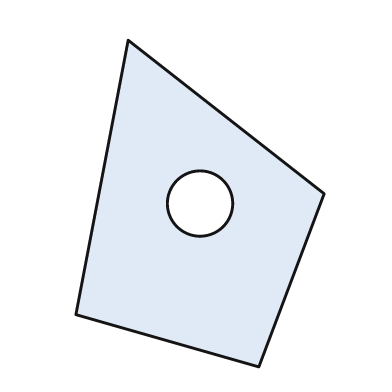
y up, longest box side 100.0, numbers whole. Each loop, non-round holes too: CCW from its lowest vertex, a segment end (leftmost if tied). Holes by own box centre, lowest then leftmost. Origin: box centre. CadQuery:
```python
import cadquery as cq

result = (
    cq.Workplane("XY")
    .moveTo(18.0, -50.0)
    .lineTo(38.0, 3.0)
    .lineTo(-22.0, 50.0)
    .lineTo(-38.0, -34.0)
    .close()
    .moveTo(0.0, 0.0)
    .circle(10.0)
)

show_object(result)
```